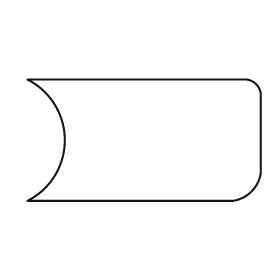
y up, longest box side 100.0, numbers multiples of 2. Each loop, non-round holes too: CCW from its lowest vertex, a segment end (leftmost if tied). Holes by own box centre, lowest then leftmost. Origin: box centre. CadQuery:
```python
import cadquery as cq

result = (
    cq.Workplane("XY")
    .moveTo(-50.0, -26.0)
    .lineTo(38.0, -26.0)
    .threePointArc((46.0, -22.0), (50.0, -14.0))
    .lineTo(50.0, 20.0)
    .threePointArc((48.0, 24.0), (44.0, 26.0))
    .lineTo(-50.0, 26.0)
    .threePointArc((-34.0, 0.0), (-50.0, -26.0))
    .close()
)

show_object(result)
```